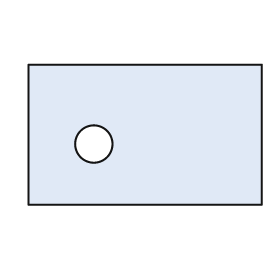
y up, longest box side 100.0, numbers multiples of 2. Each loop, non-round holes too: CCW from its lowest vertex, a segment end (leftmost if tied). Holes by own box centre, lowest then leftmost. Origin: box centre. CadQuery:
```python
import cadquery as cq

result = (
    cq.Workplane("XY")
    .moveTo(-50.0, -30.0)
    .lineTo(50.0, -30.0)
    .lineTo(50.0, 30.0)
    .lineTo(-50.0, 30.0)
    .close()
    .moveTo(-22.0, -4.0)
    .circle(8.0)
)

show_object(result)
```